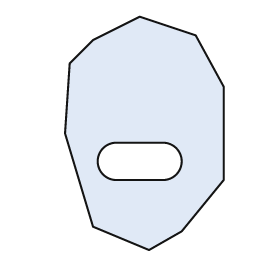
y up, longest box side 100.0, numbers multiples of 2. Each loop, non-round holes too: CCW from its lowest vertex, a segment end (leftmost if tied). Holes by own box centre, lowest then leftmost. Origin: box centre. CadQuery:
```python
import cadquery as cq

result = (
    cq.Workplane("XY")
    .moveTo(2.0, -50.0)
    .lineTo(16.0, -42.0)
    .lineTo(34.0, -20.0)
    .lineTo(34.0, 20.0)
    .lineTo(22.0, 42.0)
    .lineTo(-2.0, 50.0)
    .lineTo(-22.0, 40.0)
    .lineTo(-32.0, 30.0)
    .lineTo(-34.0, 0.0)
    .lineTo(-22.0, -40.0)
    .close()
    .moveTo(-12.0, -20.0)
    .lineTo(8.0, -20.0)
    .threePointArc((16.0, -12.0), (8.0, -4.0))
    .lineTo(-12.0, -4.0)
    .threePointArc((-20.0, -12.0), (-12.0, -20.0))
    .close()
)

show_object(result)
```